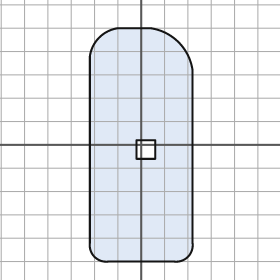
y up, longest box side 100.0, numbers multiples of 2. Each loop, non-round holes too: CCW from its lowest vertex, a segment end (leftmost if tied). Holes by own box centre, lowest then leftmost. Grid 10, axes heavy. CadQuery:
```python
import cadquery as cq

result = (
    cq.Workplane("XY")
    .moveTo(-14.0, -50.0)
    .lineTo(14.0, -50.0)
    .threePointArc((20.0, -48.0), (22.0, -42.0))
    .lineTo(22.0, 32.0)
    .threePointArc((16.0, 44.0), (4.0, 50.0))
    .lineTo(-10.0, 50.0)
    .threePointArc((-18.0, 46.0), (-22.0, 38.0))
    .lineTo(-22.0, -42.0)
    .threePointArc((-20.0, -48.0), (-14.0, -50.0))
    .close()
    .moveTo(-2.0, -6.0)
    .lineTo(6.0, -6.0)
    .lineTo(6.0, 2.0)
    .lineTo(-2.0, 2.0)
    .close()
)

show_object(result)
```